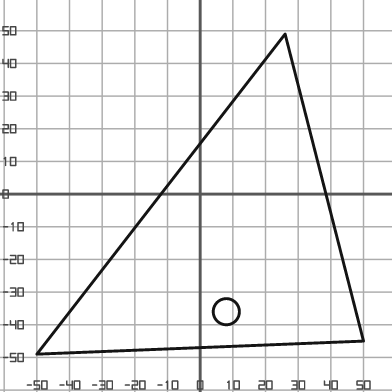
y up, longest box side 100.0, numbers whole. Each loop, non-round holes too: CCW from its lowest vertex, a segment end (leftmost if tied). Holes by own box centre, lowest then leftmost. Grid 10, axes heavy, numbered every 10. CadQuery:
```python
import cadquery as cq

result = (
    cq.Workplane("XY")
    .moveTo(-50.0, -49.0)
    .lineTo(50.0, -45.0)
    .lineTo(26.0, 49.0)
    .close()
    .moveTo(8.0, -36.0)
    .circle(4.0)
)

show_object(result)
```